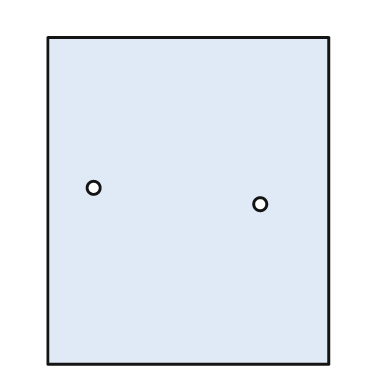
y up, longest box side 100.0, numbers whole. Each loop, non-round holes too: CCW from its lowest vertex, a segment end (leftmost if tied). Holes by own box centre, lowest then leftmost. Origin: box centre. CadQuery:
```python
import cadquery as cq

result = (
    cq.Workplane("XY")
    .moveTo(-43.0, -50.0)
    .lineTo(43.0, -50.0)
    .lineTo(43.0, 50.0)
    .lineTo(-43.0, 50.0)
    .close()
    .moveTo(22.0, -1.0)
    .circle(2.0)
    .moveTo(-29.0, 4.0)
    .circle(2.0)
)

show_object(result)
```